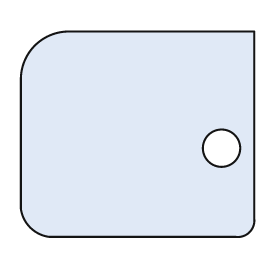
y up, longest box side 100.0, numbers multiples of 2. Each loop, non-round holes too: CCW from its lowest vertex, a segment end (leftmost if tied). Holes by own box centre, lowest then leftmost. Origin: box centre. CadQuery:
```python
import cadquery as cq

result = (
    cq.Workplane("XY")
    .moveTo(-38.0, -44.0)
    .lineTo(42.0, -44.0)
    .threePointArc((48.0, -42.0), (50.0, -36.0))
    .lineTo(50.0, 44.0)
    .lineTo(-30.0, 44.0)
    .threePointArc((-44.0, 38.0), (-50.0, 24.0))
    .lineTo(-50.0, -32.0)
    .threePointArc((-46.0, -40.0), (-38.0, -44.0))
    .close()
    .moveTo(36.0, -6.0)
    .circle(8.0)
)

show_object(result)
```